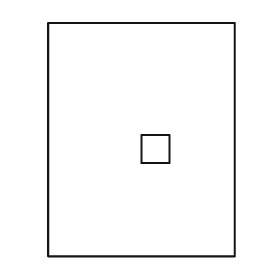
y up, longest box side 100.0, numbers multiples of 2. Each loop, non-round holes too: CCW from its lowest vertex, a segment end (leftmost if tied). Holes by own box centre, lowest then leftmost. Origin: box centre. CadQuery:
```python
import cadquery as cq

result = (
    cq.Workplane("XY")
    .moveTo(-40.0, -50.0)
    .lineTo(40.0, -50.0)
    .lineTo(40.0, 50.0)
    .lineTo(-40.0, 50.0)
    .close()
    .moveTo(0.0, -10.0)
    .lineTo(12.0, -10.0)
    .lineTo(12.0, 2.0)
    .lineTo(0.0, 2.0)
    .close()
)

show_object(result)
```